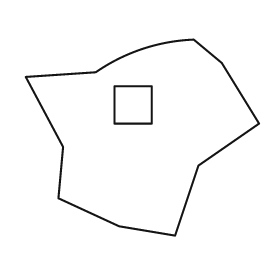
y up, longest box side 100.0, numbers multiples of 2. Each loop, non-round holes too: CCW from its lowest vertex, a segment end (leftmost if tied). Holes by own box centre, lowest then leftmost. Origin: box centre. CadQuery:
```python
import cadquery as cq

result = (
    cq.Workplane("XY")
    .moveTo(14.0, -42.0)
    .lineTo(24.0, -12.0)
    .lineTo(50.0, 6.0)
    .lineTo(34.0, 32.0)
    .lineTo(22.0, 42.0)
    .threePointArc((0.0, 38.0), (-20.0, 28.0))
    .lineTo(-50.0, 26.0)
    .lineTo(-34.0, -4.0)
    .lineTo(-36.0, -26.0)
    .lineTo(-10.0, -38.0)
    .close()
    .moveTo(-12.0, 6.0)
    .lineTo(4.0, 6.0)
    .lineTo(4.0, 22.0)
    .lineTo(-12.0, 22.0)
    .close()
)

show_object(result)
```